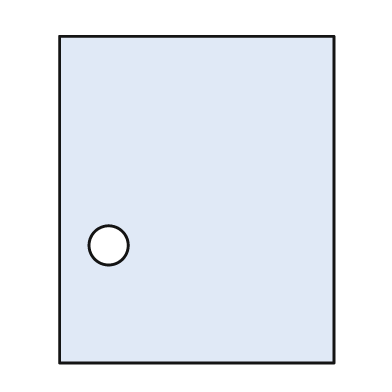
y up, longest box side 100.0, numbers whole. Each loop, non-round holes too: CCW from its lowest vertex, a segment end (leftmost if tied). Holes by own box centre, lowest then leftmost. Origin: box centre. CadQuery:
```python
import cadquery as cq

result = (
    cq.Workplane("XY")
    .moveTo(-42.0, -50.0)
    .lineTo(42.0, -50.0)
    .lineTo(42.0, 50.0)
    .lineTo(-42.0, 50.0)
    .close()
    .moveTo(-27.0, -14.0)
    .circle(6.0)
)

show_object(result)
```